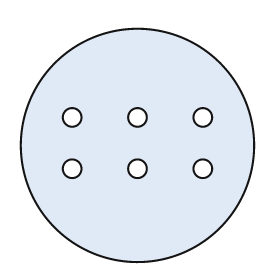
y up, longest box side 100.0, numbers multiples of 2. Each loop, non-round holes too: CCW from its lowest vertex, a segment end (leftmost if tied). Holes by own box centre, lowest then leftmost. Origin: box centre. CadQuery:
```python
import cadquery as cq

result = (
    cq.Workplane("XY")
    .moveTo(0.0, 0.0)
    .circle(50.0)
    .moveTo(-28.0, -10.0)
    .circle(4.0)
    .moveTo(0.0, -10.0)
    .circle(4.0)
    .moveTo(28.0, -10.0)
    .circle(4.0)
    .moveTo(-28.0, 12.0)
    .circle(4.0)
    .moveTo(0.0, 12.0)
    .circle(4.0)
    .moveTo(28.0, 12.0)
    .circle(4.0)
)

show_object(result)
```